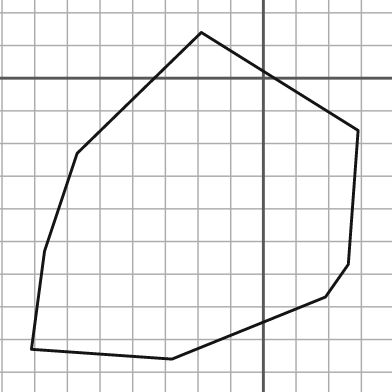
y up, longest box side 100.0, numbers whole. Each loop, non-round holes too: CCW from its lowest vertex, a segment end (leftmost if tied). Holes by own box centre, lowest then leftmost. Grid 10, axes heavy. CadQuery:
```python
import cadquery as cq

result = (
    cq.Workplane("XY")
    .moveTo(-28.0, -86.0)
    .lineTo(19.0, -67.0)
    .lineTo(26.0, -57.0)
    .lineTo(29.0, -16.0)
    .lineTo(-19.0, 14.0)
    .lineTo(-57.0, -23.0)
    .lineTo(-67.0, -53.0)
    .lineTo(-71.0, -83.0)
    .close()
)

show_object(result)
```